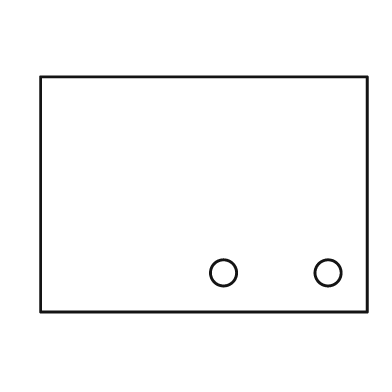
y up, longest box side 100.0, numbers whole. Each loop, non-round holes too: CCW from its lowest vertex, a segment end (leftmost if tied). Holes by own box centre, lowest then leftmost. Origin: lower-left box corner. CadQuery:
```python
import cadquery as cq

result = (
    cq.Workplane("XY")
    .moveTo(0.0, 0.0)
    .lineTo(100.0, 0.0)
    .lineTo(100.0, 72.0)
    .lineTo(0.0, 72.0)
    .close()
    .moveTo(56.0, 12.0)
    .circle(4.0)
    .moveTo(88.0, 12.0)
    .circle(4.0)
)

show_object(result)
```